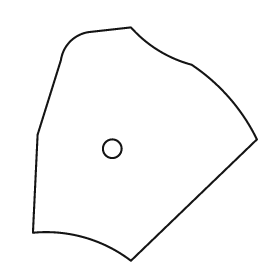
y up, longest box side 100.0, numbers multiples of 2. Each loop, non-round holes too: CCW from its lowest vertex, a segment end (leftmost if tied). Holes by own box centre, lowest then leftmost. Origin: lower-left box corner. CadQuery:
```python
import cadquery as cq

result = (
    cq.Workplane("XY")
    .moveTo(42.0, 0.0)
    .lineTo(96.0, 52.0)
    .threePointArc((84.0, 70.0), (68.0, 84.0))
    .threePointArc((54.0, 90.0), (42.0, 100.0))
    .lineTo(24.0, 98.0)
    .threePointArc((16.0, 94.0), (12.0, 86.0))
    .lineTo(2.0, 54.0)
    .lineTo(0.0, 12.0)
    .threePointArc((22.0, 10.0), (42.0, 0.0))
    .close()
    .moveTo(34.0, 48.0)
    .circle(4.0)
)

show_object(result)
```